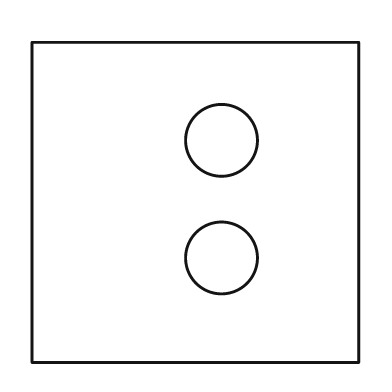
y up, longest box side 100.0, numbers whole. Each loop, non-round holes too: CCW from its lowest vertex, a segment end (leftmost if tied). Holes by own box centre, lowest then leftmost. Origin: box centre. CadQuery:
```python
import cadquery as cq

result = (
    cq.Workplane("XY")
    .moveTo(-50.0, -49.0)
    .lineTo(50.0, -49.0)
    .lineTo(50.0, 49.0)
    .lineTo(-50.0, 49.0)
    .close()
    .moveTo(8.0, -17.0)
    .circle(11.0)
    .moveTo(8.0, 19.0)
    .circle(11.0)
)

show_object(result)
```